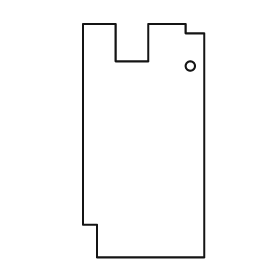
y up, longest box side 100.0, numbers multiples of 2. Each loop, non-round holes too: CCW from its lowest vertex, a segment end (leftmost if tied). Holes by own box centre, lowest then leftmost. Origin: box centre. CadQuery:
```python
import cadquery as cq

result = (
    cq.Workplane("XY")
    .moveTo(-20.0, -50.0)
    .lineTo(26.0, -50.0)
    .lineTo(26.0, 46.0)
    .lineTo(18.0, 46.0)
    .lineTo(18.0, 50.0)
    .lineTo(2.0, 50.0)
    .lineTo(2.0, 34.0)
    .lineTo(-12.0, 34.0)
    .lineTo(-12.0, 50.0)
    .lineTo(-26.0, 50.0)
    .lineTo(-26.0, -36.0)
    .lineTo(-20.0, -36.0)
    .close()
    .moveTo(20.0, 32.0)
    .circle(2.0)
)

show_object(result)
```